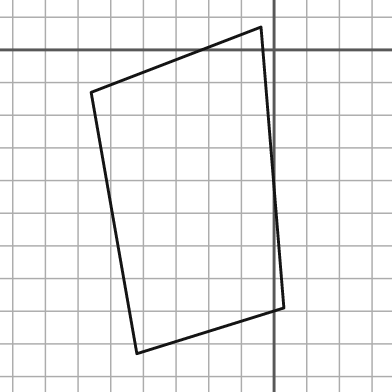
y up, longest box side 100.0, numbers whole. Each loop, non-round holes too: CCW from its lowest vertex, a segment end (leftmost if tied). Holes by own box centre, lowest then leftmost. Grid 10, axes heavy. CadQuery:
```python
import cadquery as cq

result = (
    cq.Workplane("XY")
    .moveTo(-42.0, -93.0)
    .lineTo(3.0, -79.0)
    .lineTo(-4.0, 7.0)
    .lineTo(-56.0, -13.0)
    .close()
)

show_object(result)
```